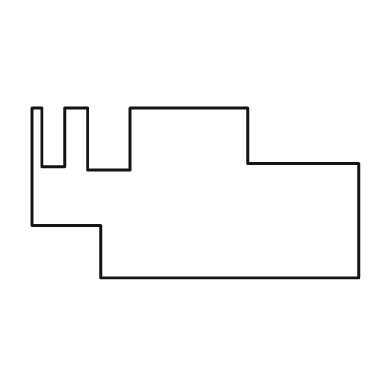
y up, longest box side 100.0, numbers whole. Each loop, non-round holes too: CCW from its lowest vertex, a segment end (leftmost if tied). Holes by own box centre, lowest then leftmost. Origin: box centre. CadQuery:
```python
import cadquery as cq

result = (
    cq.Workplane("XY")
    .moveTo(-29.0, -26.0)
    .lineTo(50.0, -26.0)
    .lineTo(50.0, 9.0)
    .lineTo(16.0, 9.0)
    .lineTo(16.0, 26.0)
    .lineTo(-20.0, 26.0)
    .lineTo(-20.0, 7.0)
    .lineTo(-33.0, 7.0)
    .lineTo(-33.0, 26.0)
    .lineTo(-40.0, 26.0)
    .lineTo(-40.0, 8.0)
    .lineTo(-47.0, 8.0)
    .lineTo(-47.0, 26.0)
    .lineTo(-50.0, 26.0)
    .lineTo(-50.0, -10.0)
    .lineTo(-29.0, -10.0)
    .close()
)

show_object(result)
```